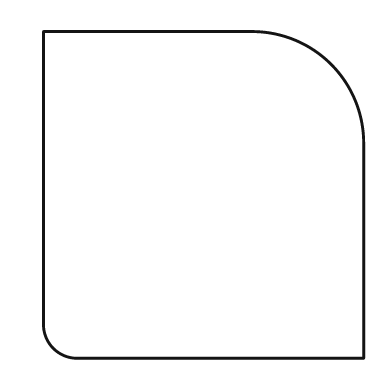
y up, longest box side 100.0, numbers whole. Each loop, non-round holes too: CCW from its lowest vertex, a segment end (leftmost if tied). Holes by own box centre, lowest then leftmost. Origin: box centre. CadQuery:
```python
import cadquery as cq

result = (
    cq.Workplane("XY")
    .moveTo(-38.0, -50.0)
    .lineTo(49.0, -50.0)
    .lineTo(49.0, 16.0)
    .threePointArc((39.0, 40.0), (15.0, 50.0))
    .lineTo(-49.0, 50.0)
    .lineTo(-49.0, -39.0)
    .threePointArc((-46.0, -47.0), (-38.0, -50.0))
    .close()
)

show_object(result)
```